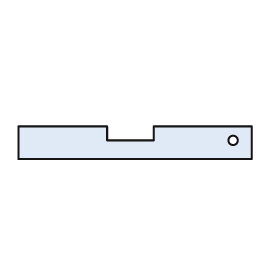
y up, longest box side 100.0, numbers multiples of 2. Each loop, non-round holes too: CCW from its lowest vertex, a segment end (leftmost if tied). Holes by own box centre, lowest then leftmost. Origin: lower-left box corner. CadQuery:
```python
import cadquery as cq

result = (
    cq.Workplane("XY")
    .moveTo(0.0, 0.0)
    .lineTo(100.0, 0.0)
    .lineTo(100.0, 14.0)
    .lineTo(58.0, 14.0)
    .lineTo(58.0, 8.0)
    .lineTo(38.0, 8.0)
    .lineTo(38.0, 14.0)
    .lineTo(0.0, 14.0)
    .close()
    .moveTo(92.0, 8.0)
    .circle(2.0)
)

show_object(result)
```